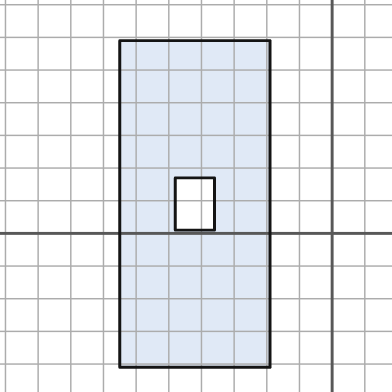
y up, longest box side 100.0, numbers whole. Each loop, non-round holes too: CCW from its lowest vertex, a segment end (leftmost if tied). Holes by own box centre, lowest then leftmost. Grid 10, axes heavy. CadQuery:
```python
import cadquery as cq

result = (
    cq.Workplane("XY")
    .moveTo(-65.0, -41.0)
    .lineTo(-19.0, -41.0)
    .lineTo(-19.0, 59.0)
    .lineTo(-65.0, 59.0)
    .close()
    .moveTo(-48.0, 1.0)
    .lineTo(-36.0, 1.0)
    .lineTo(-36.0, 17.0)
    .lineTo(-48.0, 17.0)
    .close()
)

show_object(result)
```